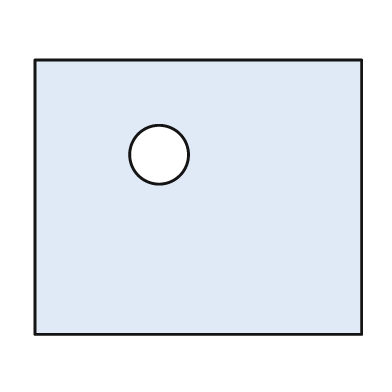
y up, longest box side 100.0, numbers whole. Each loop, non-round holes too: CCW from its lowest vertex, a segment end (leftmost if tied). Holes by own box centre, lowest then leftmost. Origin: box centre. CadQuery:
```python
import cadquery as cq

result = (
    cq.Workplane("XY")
    .moveTo(-50.0, -42.0)
    .lineTo(50.0, -42.0)
    .lineTo(50.0, 42.0)
    .lineTo(-50.0, 42.0)
    .close()
    .moveTo(-12.0, 13.0)
    .circle(9.0)
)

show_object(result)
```